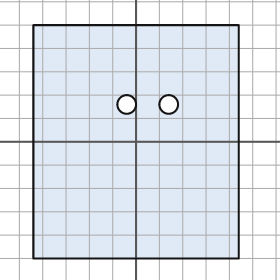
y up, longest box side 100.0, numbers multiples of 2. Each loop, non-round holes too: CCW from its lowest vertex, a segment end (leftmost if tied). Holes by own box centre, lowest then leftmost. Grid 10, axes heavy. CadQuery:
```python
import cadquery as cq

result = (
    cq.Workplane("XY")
    .moveTo(-44.0, -50.0)
    .lineTo(44.0, -50.0)
    .lineTo(44.0, 50.0)
    .lineTo(-44.0, 50.0)
    .close()
    .moveTo(-4.0, 16.0)
    .circle(4.0)
    .moveTo(14.0, 16.0)
    .circle(4.0)
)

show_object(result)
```